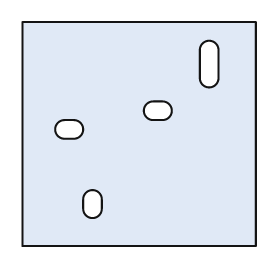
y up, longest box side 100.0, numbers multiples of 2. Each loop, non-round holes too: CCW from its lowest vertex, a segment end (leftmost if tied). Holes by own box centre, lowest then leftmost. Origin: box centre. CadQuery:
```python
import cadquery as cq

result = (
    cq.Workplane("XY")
    .moveTo(-50.0, -48.0)
    .lineTo(50.0, -48.0)
    .lineTo(50.0, 48.0)
    .lineTo(-50.0, 48.0)
    .close()
    .moveTo(-24.0, -32.0)
    .threePointArc((-20.0, -36.0), (-16.0, -32.0))
    .lineTo(-16.0, -28.0)
    .threePointArc((-20.0, -24.0), (-24.0, -28.0))
    .close()
    .moveTo(-32.0, -2.0)
    .lineTo(-28.0, -2.0)
    .threePointArc((-24.0, 2.0), (-28.0, 6.0))
    .lineTo(-32.0, 6.0)
    .threePointArc((-36.0, 2.0), (-32.0, -2.0))
    .close()
    .moveTo(6.0, 6.0)
    .lineTo(10.0, 6.0)
    .threePointArc((14.0, 10.0), (10.0, 14.0))
    .lineTo(6.0, 14.0)
    .threePointArc((2.0, 10.0), (6.0, 6.0))
    .close()
    .moveTo(26.0, 24.0)
    .threePointArc((30.0, 20.0), (34.0, 24.0))
    .lineTo(34.0, 36.0)
    .threePointArc((30.0, 40.0), (26.0, 36.0))
    .close()
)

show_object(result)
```